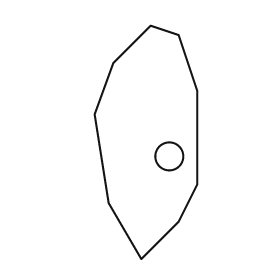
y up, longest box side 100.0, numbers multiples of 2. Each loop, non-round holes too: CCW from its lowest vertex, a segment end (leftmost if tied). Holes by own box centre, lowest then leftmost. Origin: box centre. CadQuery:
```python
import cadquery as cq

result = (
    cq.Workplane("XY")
    .moveTo(-2.0, -50.0)
    .lineTo(14.0, -34.0)
    .lineTo(22.0, -18.0)
    .lineTo(22.0, 22.0)
    .lineTo(14.0, 46.0)
    .lineTo(2.0, 50.0)
    .lineTo(-14.0, 34.0)
    .lineTo(-22.0, 12.0)
    .lineTo(-16.0, -26.0)
    .close()
    .moveTo(10.0, -6.0)
    .circle(6.0)
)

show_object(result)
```